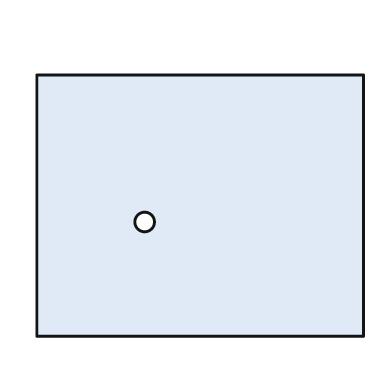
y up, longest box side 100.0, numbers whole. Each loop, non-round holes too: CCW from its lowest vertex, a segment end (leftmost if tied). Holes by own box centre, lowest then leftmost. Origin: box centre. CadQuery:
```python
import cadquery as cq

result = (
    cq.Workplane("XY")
    .moveTo(-50.0, -40.0)
    .lineTo(50.0, -40.0)
    .lineTo(50.0, 40.0)
    .lineTo(-50.0, 40.0)
    .close()
    .moveTo(-17.0, -5.0)
    .circle(3.0)
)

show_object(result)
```